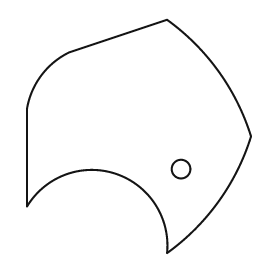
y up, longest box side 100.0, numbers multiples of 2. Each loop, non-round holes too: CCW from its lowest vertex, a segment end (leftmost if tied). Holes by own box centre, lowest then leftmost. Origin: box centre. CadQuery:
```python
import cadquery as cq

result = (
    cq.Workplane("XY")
    .moveTo(12.0, -50.0)
    .threePointArc((34.0, -28.0), (48.0, 0.0))
    .threePointArc((34.0, 28.0), (12.0, 50.0))
    .lineTo(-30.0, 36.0)
    .threePointArc((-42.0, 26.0), (-48.0, 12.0))
    .lineTo(-48.0, -30.0)
    .threePointArc((-10.0, -16.0), (12.0, -50.0))
    .close()
    .moveTo(18.0, -14.0)
    .circle(4.0)
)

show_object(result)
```